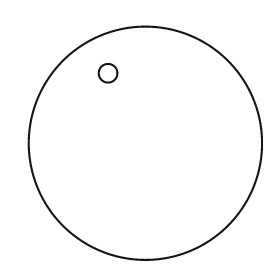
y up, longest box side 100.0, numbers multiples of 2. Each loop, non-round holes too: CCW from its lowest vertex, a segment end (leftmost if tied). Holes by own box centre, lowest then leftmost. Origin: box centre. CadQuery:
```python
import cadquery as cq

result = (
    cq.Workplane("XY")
    .moveTo(0.0, 0.0)
    .circle(50.0)
    .moveTo(-16.0, 30.0)
    .circle(4.0)
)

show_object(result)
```